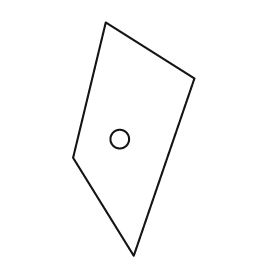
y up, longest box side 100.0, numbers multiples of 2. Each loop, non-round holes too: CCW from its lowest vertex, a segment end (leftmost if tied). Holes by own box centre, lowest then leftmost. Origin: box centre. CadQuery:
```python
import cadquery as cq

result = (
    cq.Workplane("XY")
    .moveTo(0.0, -50.0)
    .lineTo(26.0, 26.0)
    .lineTo(-12.0, 50.0)
    .lineTo(-26.0, -8.0)
    .close()
    .moveTo(-6.0, 0.0)
    .circle(4.0)
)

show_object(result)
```